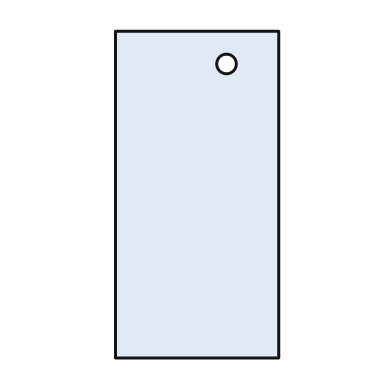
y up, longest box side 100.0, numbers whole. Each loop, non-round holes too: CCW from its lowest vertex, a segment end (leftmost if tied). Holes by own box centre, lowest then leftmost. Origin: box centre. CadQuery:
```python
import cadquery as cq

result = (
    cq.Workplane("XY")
    .moveTo(-25.0, -50.0)
    .lineTo(25.0, -50.0)
    .lineTo(25.0, 50.0)
    .lineTo(-25.0, 50.0)
    .close()
    .moveTo(9.0, 40.0)
    .circle(3.0)
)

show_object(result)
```